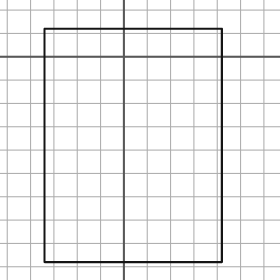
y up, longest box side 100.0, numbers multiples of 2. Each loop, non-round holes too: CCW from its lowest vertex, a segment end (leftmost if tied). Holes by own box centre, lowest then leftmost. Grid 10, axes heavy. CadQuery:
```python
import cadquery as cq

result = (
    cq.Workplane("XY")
    .moveTo(-34.0, -88.0)
    .lineTo(42.0, -88.0)
    .lineTo(42.0, 12.0)
    .lineTo(-34.0, 12.0)
    .close()
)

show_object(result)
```